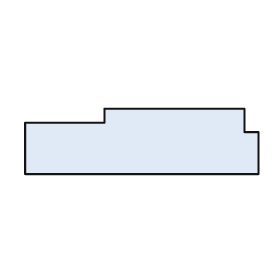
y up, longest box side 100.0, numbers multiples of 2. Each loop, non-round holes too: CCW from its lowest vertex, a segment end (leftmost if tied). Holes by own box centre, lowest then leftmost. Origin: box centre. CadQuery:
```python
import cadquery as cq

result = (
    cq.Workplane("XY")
    .moveTo(-50.0, -14.0)
    .lineTo(50.0, -14.0)
    .lineTo(50.0, 4.0)
    .lineTo(44.0, 4.0)
    .lineTo(44.0, 14.0)
    .lineTo(-16.0, 14.0)
    .lineTo(-16.0, 8.0)
    .lineTo(-50.0, 8.0)
    .close()
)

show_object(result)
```